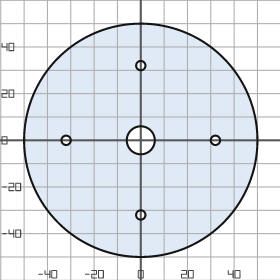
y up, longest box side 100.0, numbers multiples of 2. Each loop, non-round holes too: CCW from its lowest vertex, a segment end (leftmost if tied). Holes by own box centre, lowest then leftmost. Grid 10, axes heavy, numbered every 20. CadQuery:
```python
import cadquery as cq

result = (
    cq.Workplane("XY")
    .moveTo(0.0, 0.0)
    .circle(50.0)
    .moveTo(0.0, -32.0)
    .circle(2.0)
    .moveTo(-32.0, 0.0)
    .circle(2.0)
    .moveTo(0.0, 0.0)
    .circle(6.0)
    .moveTo(32.0, 0.0)
    .circle(2.0)
    .moveTo(0.0, 32.0)
    .circle(2.0)
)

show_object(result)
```